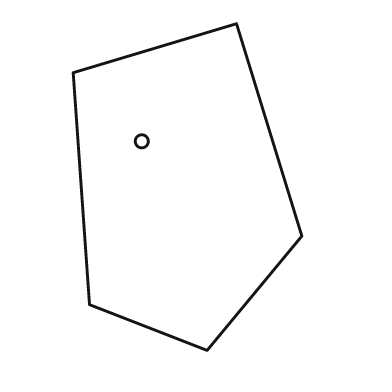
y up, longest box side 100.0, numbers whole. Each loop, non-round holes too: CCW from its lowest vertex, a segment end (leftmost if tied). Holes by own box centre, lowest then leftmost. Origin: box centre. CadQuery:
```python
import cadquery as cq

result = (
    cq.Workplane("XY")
    .moveTo(6.0, -50.0)
    .lineTo(35.0, -15.0)
    .lineTo(15.0, 50.0)
    .lineTo(-35.0, 35.0)
    .lineTo(-30.0, -36.0)
    .close()
    .moveTo(-14.0, 14.0)
    .circle(2.0)
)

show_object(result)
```